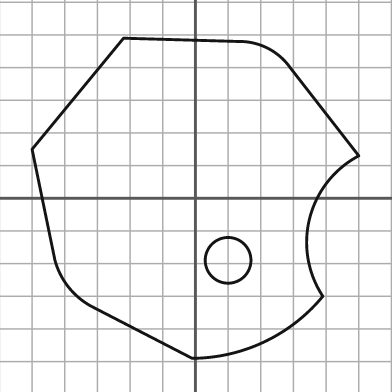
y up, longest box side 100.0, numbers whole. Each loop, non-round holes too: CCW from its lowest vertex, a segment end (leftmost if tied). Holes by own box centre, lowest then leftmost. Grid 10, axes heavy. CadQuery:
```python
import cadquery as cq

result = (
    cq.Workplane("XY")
    .moveTo(-1.0, -49.0)
    .threePointArc((21.0, -44.0), (39.0, -30.0))
    .threePointArc((35.0, -6.0), (50.0, 13.0))
    .lineTo(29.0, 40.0)
    .threePointArc((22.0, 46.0), (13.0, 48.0))
    .lineTo(-22.0, 49.0)
    .lineTo(-50.0, 15.0)
    .lineTo(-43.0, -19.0)
    .threePointArc((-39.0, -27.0), (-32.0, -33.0))
    .close()
    .moveTo(10.0, -19.0)
    .circle(7.0)
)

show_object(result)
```